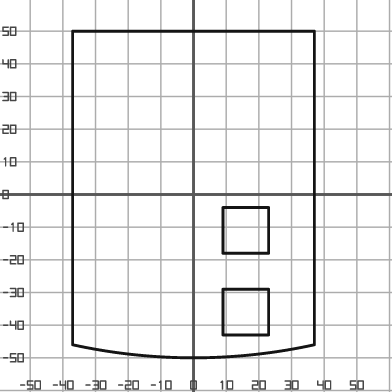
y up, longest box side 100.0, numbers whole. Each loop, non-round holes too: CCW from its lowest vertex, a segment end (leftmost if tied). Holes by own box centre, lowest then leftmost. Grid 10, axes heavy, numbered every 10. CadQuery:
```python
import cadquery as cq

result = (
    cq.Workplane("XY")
    .moveTo(-37.0, -46.0)
    .threePointArc((0.0, -50.0), (37.0, -46.0))
    .lineTo(37.0, 50.0)
    .lineTo(-37.0, 50.0)
    .close()
    .moveTo(9.0, -43.0)
    .lineTo(23.0, -43.0)
    .lineTo(23.0, -29.0)
    .lineTo(9.0, -29.0)
    .close()
    .moveTo(9.0, -18.0)
    .lineTo(23.0, -18.0)
    .lineTo(23.0, -4.0)
    .lineTo(9.0, -4.0)
    .close()
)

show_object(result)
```